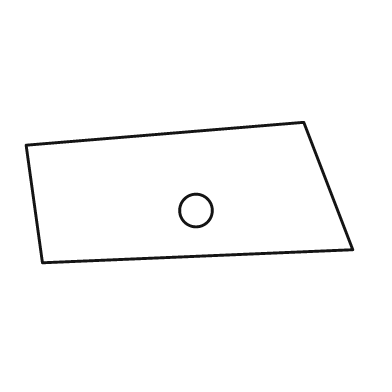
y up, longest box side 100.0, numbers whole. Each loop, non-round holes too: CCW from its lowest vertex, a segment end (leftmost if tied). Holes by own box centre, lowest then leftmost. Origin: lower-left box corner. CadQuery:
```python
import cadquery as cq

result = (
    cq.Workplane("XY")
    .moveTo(5.0, 0.0)
    .lineTo(100.0, 4.0)
    .lineTo(85.0, 43.0)
    .lineTo(0.0, 36.0)
    .close()
    .moveTo(52.0, 16.0)
    .circle(5.0)
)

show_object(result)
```